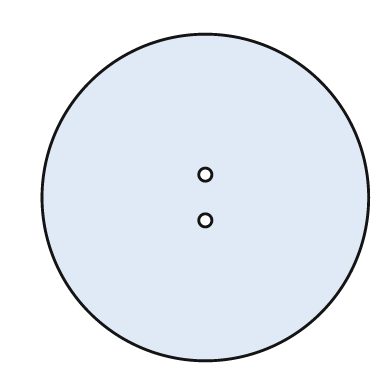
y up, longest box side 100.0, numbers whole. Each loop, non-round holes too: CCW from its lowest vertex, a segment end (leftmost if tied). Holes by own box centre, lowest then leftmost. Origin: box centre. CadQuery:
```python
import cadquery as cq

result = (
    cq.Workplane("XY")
    .moveTo(0.0, 0.0)
    .circle(50.0)
    .moveTo(0.0, -7.0)
    .circle(2.0)
    .moveTo(0.0, 7.0)
    .circle(2.0)
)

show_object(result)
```